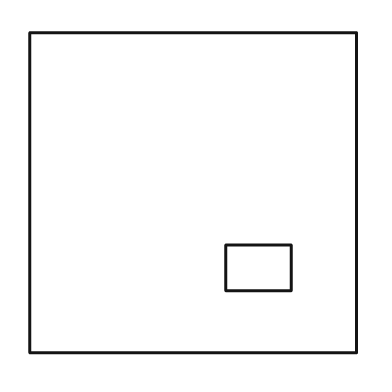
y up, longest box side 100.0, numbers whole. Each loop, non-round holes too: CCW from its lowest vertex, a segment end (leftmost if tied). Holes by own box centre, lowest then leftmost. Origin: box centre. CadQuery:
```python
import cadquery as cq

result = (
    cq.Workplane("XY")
    .moveTo(-50.0, -49.0)
    .lineTo(50.0, -49.0)
    .lineTo(50.0, 49.0)
    .lineTo(-50.0, 49.0)
    .close()
    .moveTo(10.0, -30.0)
    .lineTo(30.0, -30.0)
    .lineTo(30.0, -16.0)
    .lineTo(10.0, -16.0)
    .close()
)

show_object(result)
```